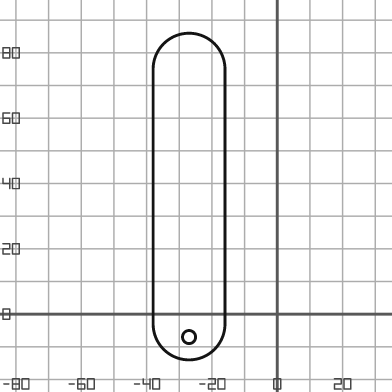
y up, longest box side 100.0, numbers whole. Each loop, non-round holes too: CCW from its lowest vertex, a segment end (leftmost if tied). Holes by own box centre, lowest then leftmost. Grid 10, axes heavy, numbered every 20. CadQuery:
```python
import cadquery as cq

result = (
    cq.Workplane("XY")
    .moveTo(-38.0, -3.0)
    .threePointArc((-27.0, -14.0), (-16.0, -3.0))
    .lineTo(-16.0, 75.0)
    .threePointArc((-27.0, 86.0), (-38.0, 75.0))
    .close()
    .moveTo(-27.0, -7.0)
    .circle(2.0)
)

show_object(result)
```